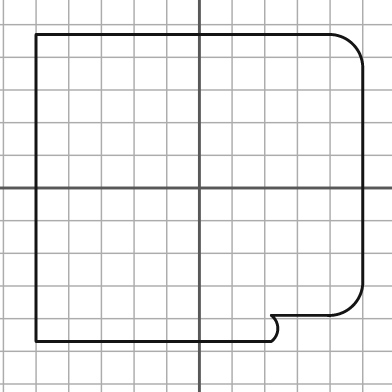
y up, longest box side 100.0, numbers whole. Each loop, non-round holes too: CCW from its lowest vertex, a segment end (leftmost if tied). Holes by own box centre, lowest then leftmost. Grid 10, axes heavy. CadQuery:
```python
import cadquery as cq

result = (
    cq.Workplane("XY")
    .moveTo(-50.0, -47.0)
    .lineTo(22.0, -47.0)
    .threePointArc((24.0, -43.0), (22.0, -39.0))
    .lineTo(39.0, -39.0)
    .threePointArc((47.0, -36.0), (50.0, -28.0))
    .lineTo(50.0, 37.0)
    .threePointArc((47.0, 44.0), (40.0, 47.0))
    .lineTo(-50.0, 47.0)
    .close()
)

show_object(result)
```